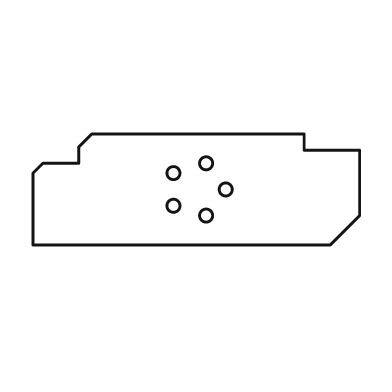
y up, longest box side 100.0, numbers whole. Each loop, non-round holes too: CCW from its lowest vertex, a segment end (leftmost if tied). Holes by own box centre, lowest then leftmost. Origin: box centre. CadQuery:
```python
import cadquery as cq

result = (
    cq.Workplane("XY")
    .moveTo(-50.0, -17.0)
    .lineTo(41.0, -17.0)
    .lineTo(50.0, -8.0)
    .lineTo(50.0, 12.0)
    .lineTo(33.0, 12.0)
    .lineTo(33.0, 17.0)
    .lineTo(-32.0, 17.0)
    .lineTo(-36.0, 13.0)
    .lineTo(-36.0, 8.0)
    .lineTo(-47.0, 8.0)
    .lineTo(-50.0, 5.0)
    .close()
    .moveTo(3.0, -8.0)
    .circle(2.0)
    .moveTo(-7.0, -5.0)
    .circle(2.0)
    .moveTo(9.0, 0.0)
    .circle(2.0)
    .moveTo(-7.0, 5.0)
    .circle(2.0)
    .moveTo(3.0, 8.0)
    .circle(2.0)
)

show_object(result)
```